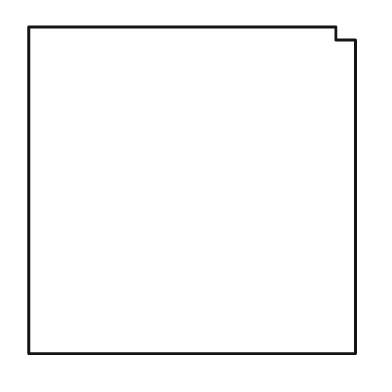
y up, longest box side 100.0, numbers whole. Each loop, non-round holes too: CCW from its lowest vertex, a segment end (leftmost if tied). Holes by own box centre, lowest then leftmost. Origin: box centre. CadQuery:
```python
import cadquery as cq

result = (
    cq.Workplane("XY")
    .moveTo(-50.0, -50.0)
    .lineTo(50.0, -50.0)
    .lineTo(50.0, 46.0)
    .lineTo(44.0, 46.0)
    .lineTo(44.0, 50.0)
    .lineTo(-50.0, 50.0)
    .close()
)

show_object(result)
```